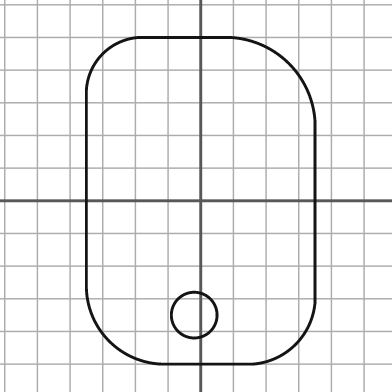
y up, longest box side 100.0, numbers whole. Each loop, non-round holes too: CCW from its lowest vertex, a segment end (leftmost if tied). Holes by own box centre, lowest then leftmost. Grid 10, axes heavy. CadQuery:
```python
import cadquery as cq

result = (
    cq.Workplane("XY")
    .moveTo(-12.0, -50.0)
    .lineTo(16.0, -50.0)
    .threePointArc((29.0, -44.0), (35.0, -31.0))
    .lineTo(35.0, 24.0)
    .threePointArc((27.0, 42.0), (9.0, 50.0))
    .lineTo(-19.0, 50.0)
    .threePointArc((-30.0, 45.0), (-35.0, 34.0))
    .lineTo(-35.0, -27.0)
    .threePointArc((-28.0, -43.0), (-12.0, -50.0))
    .close()
    .moveTo(-2.0, -35.0)
    .circle(7.0)
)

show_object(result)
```